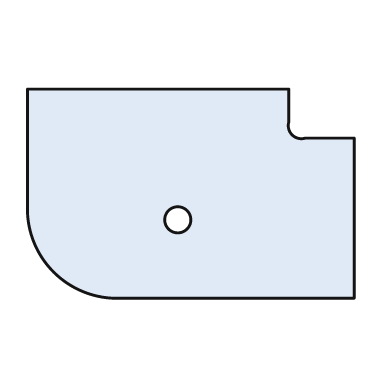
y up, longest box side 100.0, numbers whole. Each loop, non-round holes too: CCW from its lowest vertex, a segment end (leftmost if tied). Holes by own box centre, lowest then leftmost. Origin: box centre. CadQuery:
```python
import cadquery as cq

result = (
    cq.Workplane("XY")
    .moveTo(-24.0, -32.0)
    .lineTo(50.0, -32.0)
    .lineTo(50.0, 17.0)
    .lineTo(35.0, 17.0)
    .threePointArc((31.0, 18.0), (30.0, 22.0))
    .lineTo(30.0, 32.0)
    .lineTo(-50.0, 32.0)
    .lineTo(-50.0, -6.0)
    .threePointArc((-42.0, -24.0), (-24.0, -32.0))
    .close()
    .moveTo(-4.0, -8.0)
    .circle(4.0)
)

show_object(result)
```